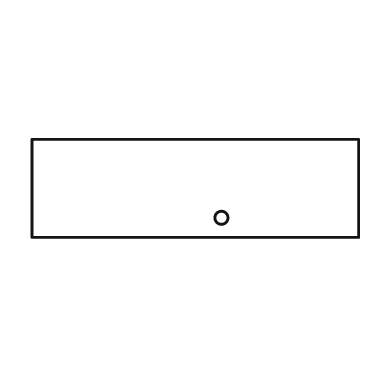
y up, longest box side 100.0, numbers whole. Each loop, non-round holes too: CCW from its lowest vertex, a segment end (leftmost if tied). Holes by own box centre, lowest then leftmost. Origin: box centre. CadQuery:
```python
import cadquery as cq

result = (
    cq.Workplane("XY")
    .moveTo(-50.0, -15.0)
    .lineTo(50.0, -15.0)
    .lineTo(50.0, 15.0)
    .lineTo(-50.0, 15.0)
    .close()
    .moveTo(8.0, -9.0)
    .circle(2.0)
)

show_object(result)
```